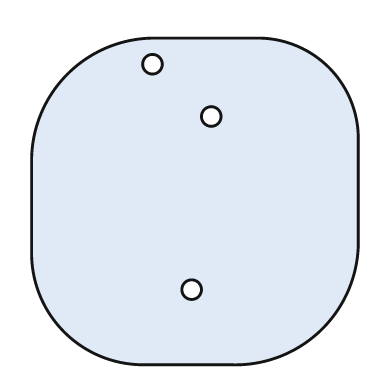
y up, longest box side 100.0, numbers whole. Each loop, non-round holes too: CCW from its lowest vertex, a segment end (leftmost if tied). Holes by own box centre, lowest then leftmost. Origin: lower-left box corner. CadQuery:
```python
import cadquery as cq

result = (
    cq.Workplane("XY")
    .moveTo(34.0, 0.0)
    .lineTo(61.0, 0.0)
    .threePointArc((89.0, 11.0), (100.0, 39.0))
    .lineTo(100.0, 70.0)
    .threePointArc((91.0, 91.0), (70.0, 100.0))
    .lineTo(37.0, 100.0)
    .threePointArc((11.0, 89.0), (0.0, 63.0))
    .lineTo(0.0, 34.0)
    .threePointArc((10.0, 10.0), (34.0, 0.0))
    .close()
    .moveTo(49.0, 23.0)
    .circle(3.0)
    .moveTo(55.0, 76.0)
    .circle(3.0)
    .moveTo(37.0, 92.0)
    .circle(3.0)
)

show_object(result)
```